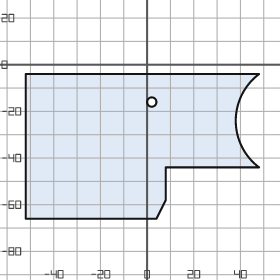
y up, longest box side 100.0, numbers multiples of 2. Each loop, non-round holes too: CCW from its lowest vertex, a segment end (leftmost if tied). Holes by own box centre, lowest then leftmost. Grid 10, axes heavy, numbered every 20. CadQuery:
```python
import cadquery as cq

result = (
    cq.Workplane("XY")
    .moveTo(-52.0, -66.0)
    .lineTo(4.0, -66.0)
    .lineTo(8.0, -58.0)
    .lineTo(8.0, -44.0)
    .lineTo(48.0, -44.0)
    .threePointArc((38.0, -24.0), (48.0, -4.0))
    .lineTo(-52.0, -4.0)
    .close()
    .moveTo(2.0, -16.0)
    .circle(2.0)
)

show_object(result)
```